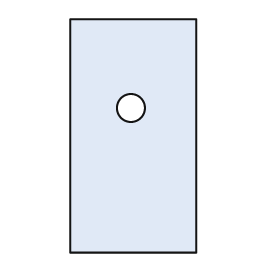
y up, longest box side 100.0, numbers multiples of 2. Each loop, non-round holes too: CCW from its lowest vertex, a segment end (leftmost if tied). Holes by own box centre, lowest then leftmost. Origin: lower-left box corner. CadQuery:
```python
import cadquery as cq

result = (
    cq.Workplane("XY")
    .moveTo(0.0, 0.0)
    .lineTo(54.0, 0.0)
    .lineTo(54.0, 100.0)
    .lineTo(0.0, 100.0)
    .close()
    .moveTo(26.0, 62.0)
    .circle(6.0)
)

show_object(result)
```